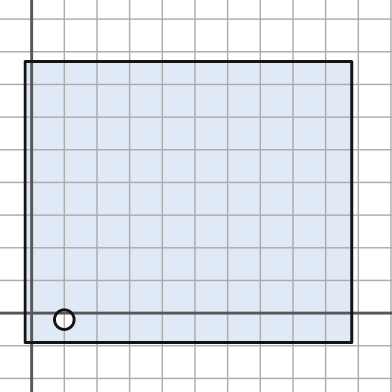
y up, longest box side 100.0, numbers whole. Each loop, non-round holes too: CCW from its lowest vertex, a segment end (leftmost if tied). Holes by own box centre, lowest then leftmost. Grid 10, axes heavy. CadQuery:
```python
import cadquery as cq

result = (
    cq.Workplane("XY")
    .moveTo(-2.0, -9.0)
    .lineTo(98.0, -9.0)
    .lineTo(98.0, 77.0)
    .lineTo(-2.0, 77.0)
    .close()
    .moveTo(10.0, -2.0)
    .circle(3.0)
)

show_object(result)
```